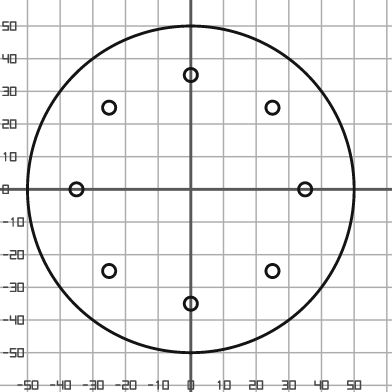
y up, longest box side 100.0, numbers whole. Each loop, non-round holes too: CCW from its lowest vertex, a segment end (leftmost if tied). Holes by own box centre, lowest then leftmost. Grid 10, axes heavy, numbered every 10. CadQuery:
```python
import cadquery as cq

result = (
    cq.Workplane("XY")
    .moveTo(0.0, 0.0)
    .circle(50.0)
    .moveTo(0.0, -35.0)
    .circle(2.0)
    .moveTo(-25.0, -25.0)
    .circle(2.0)
    .moveTo(25.0, -25.0)
    .circle(2.0)
    .moveTo(-35.0, 0.0)
    .circle(2.0)
    .moveTo(35.0, 0.0)
    .circle(2.0)
    .moveTo(-25.0, 25.0)
    .circle(2.0)
    .moveTo(25.0, 25.0)
    .circle(2.0)
    .moveTo(0.0, 35.0)
    .circle(2.0)
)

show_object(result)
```